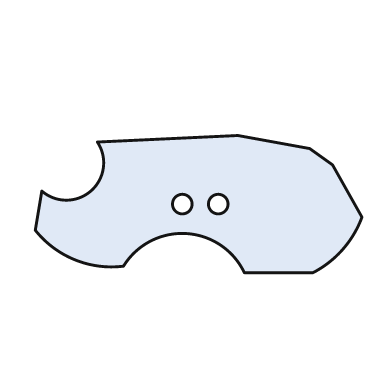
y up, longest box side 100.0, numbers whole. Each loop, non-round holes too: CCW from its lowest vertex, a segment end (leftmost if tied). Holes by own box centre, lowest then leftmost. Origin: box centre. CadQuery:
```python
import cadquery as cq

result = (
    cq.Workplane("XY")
    .moveTo(14.0, -21.0)
    .lineTo(35.0, -21.0)
    .threePointArc((44.0, -14.0), (50.0, -4.0))
    .lineTo(41.0, 12.0)
    .lineTo(34.0, 17.0)
    .lineTo(12.0, 21.0)
    .lineTo(-31.0, 19.0)
    .threePointArc((-33.0, 4.0), (-48.0, 4.0))
    .lineTo(-50.0, -8.0)
    .threePointArc((-38.0, -17.0), (-23.0, -19.0))
    .threePointArc((-4.0, -9.0), (14.0, -21.0))
    .close()
    .moveTo(-5.0, 0.0)
    .circle(3.0)
    .moveTo(6.0, 0.0)
    .circle(3.0)
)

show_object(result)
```